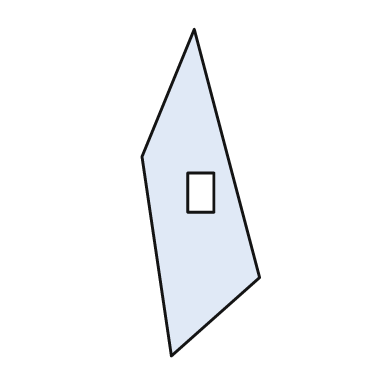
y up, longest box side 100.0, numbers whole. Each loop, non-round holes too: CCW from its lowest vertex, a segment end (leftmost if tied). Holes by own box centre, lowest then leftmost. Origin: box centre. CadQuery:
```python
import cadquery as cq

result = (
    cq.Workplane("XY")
    .moveTo(-9.0, -50.0)
    .lineTo(18.0, -26.0)
    .lineTo(-2.0, 50.0)
    .lineTo(-18.0, 11.0)
    .close()
    .moveTo(-4.0, -6.0)
    .lineTo(4.0, -6.0)
    .lineTo(4.0, 6.0)
    .lineTo(-4.0, 6.0)
    .close()
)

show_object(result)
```